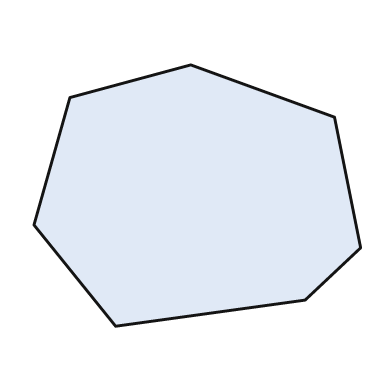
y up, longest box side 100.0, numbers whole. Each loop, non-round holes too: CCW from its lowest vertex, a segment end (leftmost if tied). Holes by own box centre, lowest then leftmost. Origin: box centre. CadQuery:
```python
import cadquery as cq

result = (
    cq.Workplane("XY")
    .moveTo(-25.0, -40.0)
    .lineTo(33.0, -32.0)
    .lineTo(50.0, -16.0)
    .lineTo(42.0, 24.0)
    .lineTo(-2.0, 40.0)
    .lineTo(-39.0, 30.0)
    .lineTo(-50.0, -9.0)
    .close()
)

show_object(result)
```